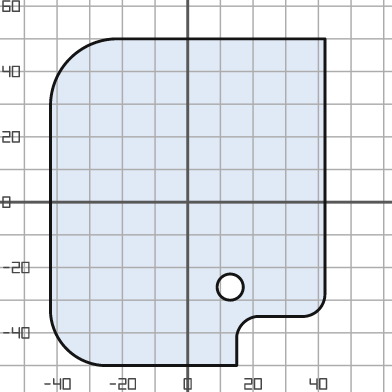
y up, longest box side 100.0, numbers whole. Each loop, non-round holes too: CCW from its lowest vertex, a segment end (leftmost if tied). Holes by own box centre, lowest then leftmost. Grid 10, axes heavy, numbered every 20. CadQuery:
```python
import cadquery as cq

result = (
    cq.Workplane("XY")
    .moveTo(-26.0, -50.0)
    .lineTo(15.0, -50.0)
    .lineTo(15.0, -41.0)
    .threePointArc((17.0, -37.0), (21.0, -35.0))
    .lineTo(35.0, -35.0)
    .threePointArc((40.0, -33.0), (42.0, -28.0))
    .lineTo(42.0, 50.0)
    .lineTo(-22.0, 50.0)
    .threePointArc((-36.0, 44.0), (-42.0, 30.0))
    .lineTo(-42.0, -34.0)
    .threePointArc((-37.0, -45.0), (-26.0, -50.0))
    .close()
    .moveTo(13.0, -26.0)
    .circle(4.0)
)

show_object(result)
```